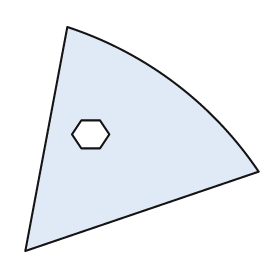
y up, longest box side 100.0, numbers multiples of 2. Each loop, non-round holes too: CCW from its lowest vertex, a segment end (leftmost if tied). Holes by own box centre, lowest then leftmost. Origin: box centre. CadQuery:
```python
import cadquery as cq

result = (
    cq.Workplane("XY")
    .moveTo(-50.0, -48.0)
    .lineTo(50.0, -14.0)
    .threePointArc((14.0, 24.0), (-32.0, 48.0))
    .close()
    .moveTo(-26.0, -4.0)
    .lineTo(-18.0, -4.0)
    .lineTo(-14.0, 2.0)
    .lineTo(-18.0, 8.0)
    .lineTo(-26.0, 8.0)
    .lineTo(-30.0, 2.0)
    .close()
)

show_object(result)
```